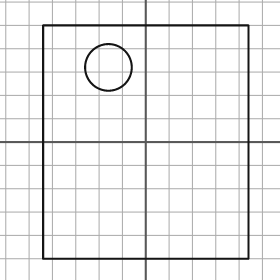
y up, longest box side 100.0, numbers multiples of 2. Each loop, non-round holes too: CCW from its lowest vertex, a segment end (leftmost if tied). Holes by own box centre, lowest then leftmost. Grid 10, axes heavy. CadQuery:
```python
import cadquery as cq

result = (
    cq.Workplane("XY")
    .moveTo(-44.0, -50.0)
    .lineTo(44.0, -50.0)
    .lineTo(44.0, 50.0)
    .lineTo(-44.0, 50.0)
    .close()
    .moveTo(-16.0, 32.0)
    .circle(10.0)
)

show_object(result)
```